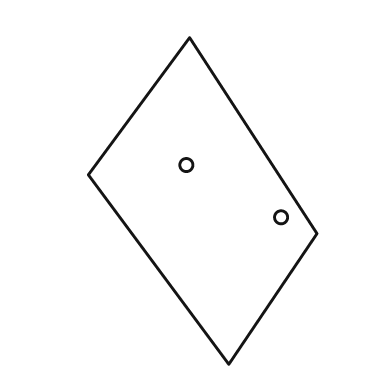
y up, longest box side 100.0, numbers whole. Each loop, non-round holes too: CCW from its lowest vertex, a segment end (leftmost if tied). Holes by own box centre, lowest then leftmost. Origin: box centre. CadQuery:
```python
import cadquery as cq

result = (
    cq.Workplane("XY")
    .moveTo(8.0, -50.0)
    .lineTo(35.0, -10.0)
    .lineTo(-4.0, 50.0)
    .lineTo(-35.0, 8.0)
    .close()
    .moveTo(24.0, -5.0)
    .circle(2.0)
    .moveTo(-5.0, 11.0)
    .circle(2.0)
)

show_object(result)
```